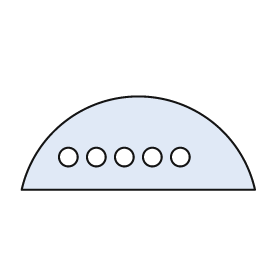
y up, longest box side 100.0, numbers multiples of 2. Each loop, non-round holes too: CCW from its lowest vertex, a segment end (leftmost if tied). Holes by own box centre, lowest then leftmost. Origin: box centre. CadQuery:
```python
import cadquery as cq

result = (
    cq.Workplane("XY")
    .moveTo(-50.0, -20.0)
    .lineTo(50.0, -20.0)
    .threePointArc((0.0, 20.0), (-50.0, -20.0))
    .close()
    .moveTo(-30.0, -6.0)
    .circle(4.0)
    .moveTo(-18.0, -6.0)
    .circle(4.0)
    .moveTo(-6.0, -6.0)
    .circle(4.0)
    .moveTo(6.0, -6.0)
    .circle(4.0)
    .moveTo(18.0, -6.0)
    .circle(4.0)
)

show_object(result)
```